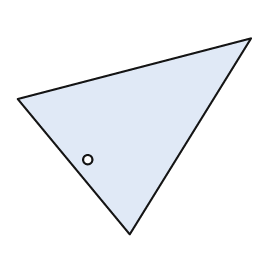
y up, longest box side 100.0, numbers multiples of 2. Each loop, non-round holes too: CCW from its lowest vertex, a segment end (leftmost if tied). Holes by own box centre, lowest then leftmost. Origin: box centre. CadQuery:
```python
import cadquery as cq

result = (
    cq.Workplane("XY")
    .moveTo(-2.0, -42.0)
    .lineTo(50.0, 42.0)
    .lineTo(-50.0, 16.0)
    .close()
    .moveTo(-20.0, -10.0)
    .circle(2.0)
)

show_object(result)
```